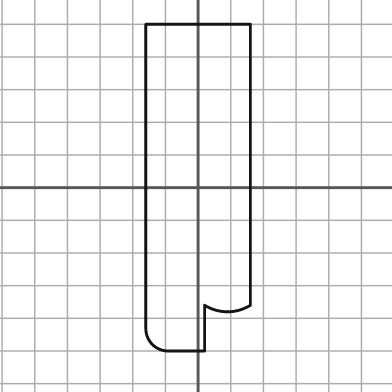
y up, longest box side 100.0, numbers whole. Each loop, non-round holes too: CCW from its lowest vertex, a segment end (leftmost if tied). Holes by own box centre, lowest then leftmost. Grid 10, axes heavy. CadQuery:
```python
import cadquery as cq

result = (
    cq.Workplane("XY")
    .moveTo(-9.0, -50.0)
    .lineTo(2.0, -50.0)
    .lineTo(2.0, -36.0)
    .threePointArc((9.0, -38.0), (16.0, -36.0))
    .lineTo(16.0, 50.0)
    .lineTo(-16.0, 50.0)
    .lineTo(-16.0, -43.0)
    .threePointArc((-14.0, -48.0), (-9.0, -50.0))
    .close()
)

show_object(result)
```